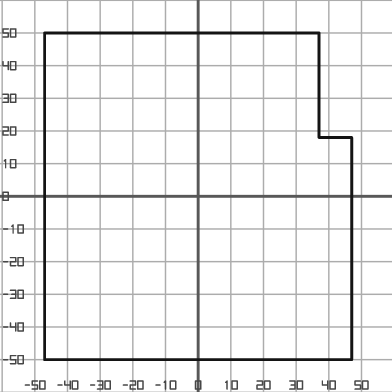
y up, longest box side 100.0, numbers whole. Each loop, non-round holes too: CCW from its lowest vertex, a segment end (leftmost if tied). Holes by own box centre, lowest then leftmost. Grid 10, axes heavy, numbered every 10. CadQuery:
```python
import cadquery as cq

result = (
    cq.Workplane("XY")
    .moveTo(-47.0, -50.0)
    .lineTo(47.0, -50.0)
    .lineTo(47.0, 18.0)
    .lineTo(37.0, 18.0)
    .lineTo(37.0, 50.0)
    .lineTo(-47.0, 50.0)
    .close()
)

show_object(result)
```